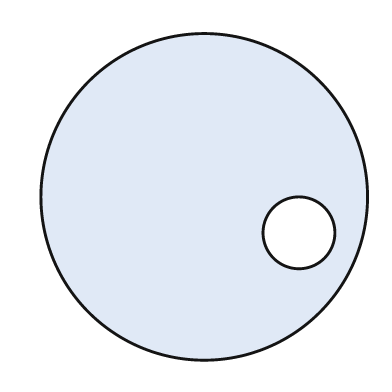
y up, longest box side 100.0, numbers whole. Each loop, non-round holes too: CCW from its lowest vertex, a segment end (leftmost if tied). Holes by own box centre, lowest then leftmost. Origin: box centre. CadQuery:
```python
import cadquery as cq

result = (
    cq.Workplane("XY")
    .moveTo(0.0, 0.0)
    .circle(50.0)
    .moveTo(29.0, -11.0)
    .circle(11.0)
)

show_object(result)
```